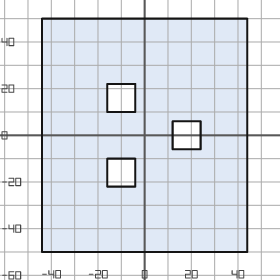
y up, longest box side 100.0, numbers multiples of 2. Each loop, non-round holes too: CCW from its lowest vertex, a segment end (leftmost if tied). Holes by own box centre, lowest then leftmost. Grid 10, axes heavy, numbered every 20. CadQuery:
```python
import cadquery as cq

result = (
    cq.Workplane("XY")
    .moveTo(-44.0, -50.0)
    .lineTo(44.0, -50.0)
    .lineTo(44.0, 50.0)
    .lineTo(-44.0, 50.0)
    .close()
    .moveTo(-16.0, -22.0)
    .lineTo(-4.0, -22.0)
    .lineTo(-4.0, -10.0)
    .lineTo(-16.0, -10.0)
    .close()
    .moveTo(12.0, -6.0)
    .lineTo(24.0, -6.0)
    .lineTo(24.0, 6.0)
    .lineTo(12.0, 6.0)
    .close()
    .moveTo(-16.0, 10.0)
    .lineTo(-4.0, 10.0)
    .lineTo(-4.0, 22.0)
    .lineTo(-16.0, 22.0)
    .close()
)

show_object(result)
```